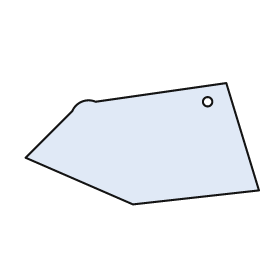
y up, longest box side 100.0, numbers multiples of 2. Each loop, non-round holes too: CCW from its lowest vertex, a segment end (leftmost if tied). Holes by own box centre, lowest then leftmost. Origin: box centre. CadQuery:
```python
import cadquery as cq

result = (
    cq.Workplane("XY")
    .moveTo(-4.0, -26.0)
    .lineTo(50.0, -20.0)
    .lineTo(36.0, 26.0)
    .lineTo(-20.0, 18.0)
    .threePointArc((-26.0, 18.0), (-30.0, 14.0))
    .lineTo(-50.0, -6.0)
    .close()
    .moveTo(28.0, 18.0)
    .circle(2.0)
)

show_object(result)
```